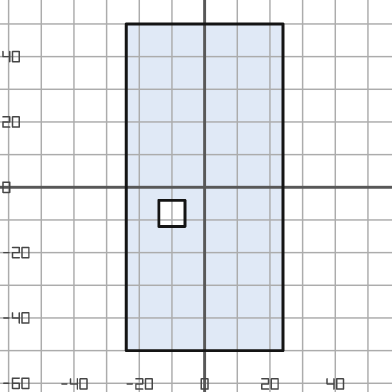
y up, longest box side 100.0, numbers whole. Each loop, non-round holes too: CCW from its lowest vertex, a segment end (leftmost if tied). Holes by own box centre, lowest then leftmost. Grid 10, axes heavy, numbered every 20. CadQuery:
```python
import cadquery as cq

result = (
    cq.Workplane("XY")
    .moveTo(-24.0, -50.0)
    .lineTo(24.0, -50.0)
    .lineTo(24.0, 50.0)
    .lineTo(-24.0, 50.0)
    .close()
    .moveTo(-14.0, -12.0)
    .lineTo(-6.0, -12.0)
    .lineTo(-6.0, -4.0)
    .lineTo(-14.0, -4.0)
    .close()
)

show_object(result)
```